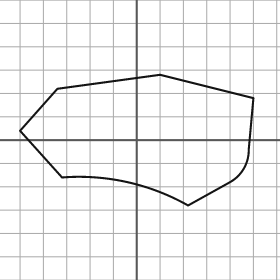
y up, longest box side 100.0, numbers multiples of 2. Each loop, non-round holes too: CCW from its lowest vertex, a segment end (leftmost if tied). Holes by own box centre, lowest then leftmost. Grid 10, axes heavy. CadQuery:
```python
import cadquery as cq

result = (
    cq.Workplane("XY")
    .moveTo(22.0, -28.0)
    .lineTo(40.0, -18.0)
    .threePointArc((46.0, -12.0), (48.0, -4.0))
    .lineTo(50.0, 18.0)
    .lineTo(10.0, 28.0)
    .lineTo(-34.0, 22.0)
    .lineTo(-50.0, 4.0)
    .lineTo(-32.0, -16.0)
    .threePointArc((-4.0, -18.0), (22.0, -28.0))
    .close()
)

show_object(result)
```